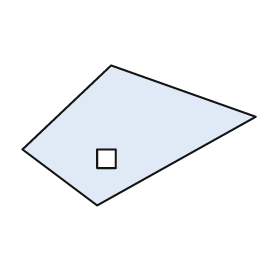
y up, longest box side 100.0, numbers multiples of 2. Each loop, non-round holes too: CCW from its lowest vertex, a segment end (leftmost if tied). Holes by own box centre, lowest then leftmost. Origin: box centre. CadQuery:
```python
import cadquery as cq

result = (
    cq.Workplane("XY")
    .moveTo(-18.0, -30.0)
    .lineTo(50.0, 8.0)
    .lineTo(-12.0, 30.0)
    .lineTo(-50.0, -6.0)
    .close()
    .moveTo(-18.0, -14.0)
    .lineTo(-10.0, -14.0)
    .lineTo(-10.0, -6.0)
    .lineTo(-18.0, -6.0)
    .close()
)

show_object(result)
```